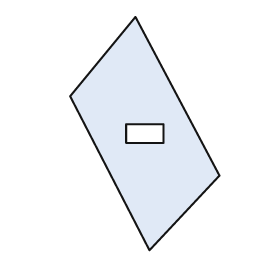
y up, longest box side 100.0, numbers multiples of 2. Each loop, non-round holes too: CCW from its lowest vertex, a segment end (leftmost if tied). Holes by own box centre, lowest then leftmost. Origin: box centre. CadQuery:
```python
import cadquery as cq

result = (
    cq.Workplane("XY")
    .moveTo(2.0, -50.0)
    .lineTo(32.0, -18.0)
    .lineTo(-4.0, 50.0)
    .lineTo(-32.0, 16.0)
    .close()
    .moveTo(-8.0, -4.0)
    .lineTo(8.0, -4.0)
    .lineTo(8.0, 4.0)
    .lineTo(-8.0, 4.0)
    .close()
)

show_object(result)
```